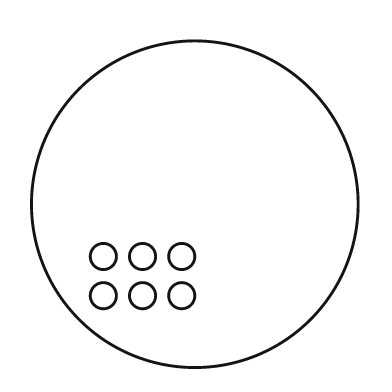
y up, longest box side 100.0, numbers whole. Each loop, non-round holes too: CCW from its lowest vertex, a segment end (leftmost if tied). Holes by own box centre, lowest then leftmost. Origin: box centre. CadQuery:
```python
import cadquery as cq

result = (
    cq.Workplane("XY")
    .moveTo(0.0, 0.0)
    .circle(50.0)
    .moveTo(-28.0, -28.0)
    .circle(4.0)
    .moveTo(-16.0, -28.0)
    .circle(4.0)
    .moveTo(-4.0, -28.0)
    .circle(4.0)
    .moveTo(-28.0, -16.0)
    .circle(4.0)
    .moveTo(-16.0, -16.0)
    .circle(4.0)
    .moveTo(-4.0, -16.0)
    .circle(4.0)
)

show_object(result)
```